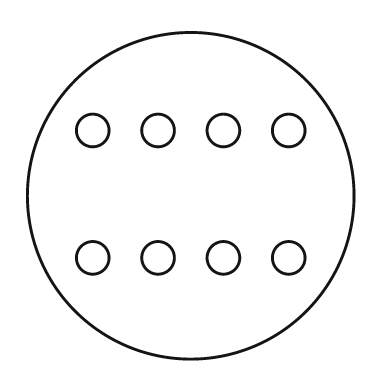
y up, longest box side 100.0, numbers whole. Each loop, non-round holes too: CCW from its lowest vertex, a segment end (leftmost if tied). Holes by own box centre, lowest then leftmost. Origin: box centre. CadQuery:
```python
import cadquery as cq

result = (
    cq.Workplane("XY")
    .moveTo(0.0, 0.0)
    .circle(50.0)
    .moveTo(-30.0, -19.0)
    .circle(5.0)
    .moveTo(-10.0, -19.0)
    .circle(5.0)
    .moveTo(10.0, -19.0)
    .circle(5.0)
    .moveTo(30.0, -19.0)
    .circle(5.0)
    .moveTo(-30.0, 20.0)
    .circle(5.0)
    .moveTo(-10.0, 20.0)
    .circle(5.0)
    .moveTo(10.0, 20.0)
    .circle(5.0)
    .moveTo(30.0, 20.0)
    .circle(5.0)
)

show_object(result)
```